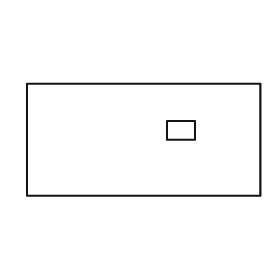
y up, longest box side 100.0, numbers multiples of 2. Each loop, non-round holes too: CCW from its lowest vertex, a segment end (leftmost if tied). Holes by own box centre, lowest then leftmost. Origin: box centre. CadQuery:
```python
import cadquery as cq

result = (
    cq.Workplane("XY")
    .moveTo(-50.0, -24.0)
    .lineTo(50.0, -24.0)
    .lineTo(50.0, 24.0)
    .lineTo(-50.0, 24.0)
    .close()
    .moveTo(10.0, 0.0)
    .lineTo(22.0, 0.0)
    .lineTo(22.0, 8.0)
    .lineTo(10.0, 8.0)
    .close()
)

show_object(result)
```